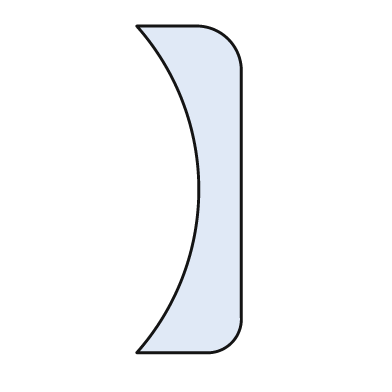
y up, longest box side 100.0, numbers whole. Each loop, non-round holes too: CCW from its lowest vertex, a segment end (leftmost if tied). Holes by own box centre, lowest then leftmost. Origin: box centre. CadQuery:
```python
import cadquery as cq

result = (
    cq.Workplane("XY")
    .moveTo(-16.0, -50.0)
    .lineTo(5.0, -50.0)
    .threePointArc((13.0, -47.0), (16.0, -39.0))
    .lineTo(16.0, 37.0)
    .threePointArc((12.0, 46.0), (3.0, 50.0))
    .lineTo(-16.0, 50.0)
    .threePointArc((3.0, 0.0), (-16.0, -50.0))
    .close()
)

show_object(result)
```